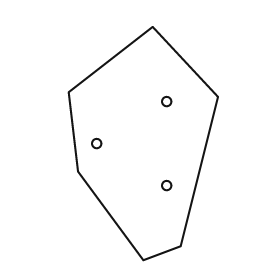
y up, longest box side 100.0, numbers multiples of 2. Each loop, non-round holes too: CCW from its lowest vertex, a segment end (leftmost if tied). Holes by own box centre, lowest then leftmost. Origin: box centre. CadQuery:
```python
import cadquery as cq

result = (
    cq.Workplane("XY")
    .moveTo(0.0, -50.0)
    .lineTo(16.0, -44.0)
    .lineTo(32.0, 20.0)
    .lineTo(4.0, 50.0)
    .lineTo(-32.0, 22.0)
    .lineTo(-28.0, -12.0)
    .close()
    .moveTo(10.0, -18.0)
    .circle(2.0)
    .moveTo(-20.0, 0.0)
    .circle(2.0)
    .moveTo(10.0, 18.0)
    .circle(2.0)
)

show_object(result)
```